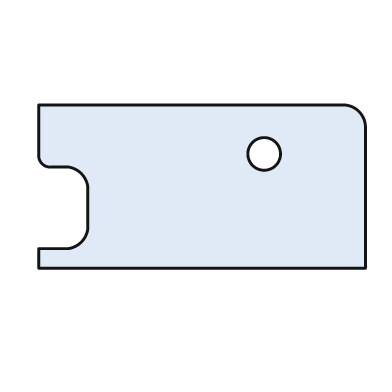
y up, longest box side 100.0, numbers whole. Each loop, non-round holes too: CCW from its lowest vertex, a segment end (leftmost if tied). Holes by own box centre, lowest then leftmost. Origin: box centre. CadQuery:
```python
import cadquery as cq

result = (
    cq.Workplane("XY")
    .moveTo(-50.0, -25.0)
    .lineTo(50.0, -25.0)
    .lineTo(50.0, 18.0)
    .threePointArc((48.0, 23.0), (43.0, 25.0))
    .lineTo(-50.0, 25.0)
    .lineTo(-50.0, 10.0)
    .threePointArc((-49.0, 7.0), (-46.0, 6.0))
    .lineTo(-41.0, 6.0)
    .threePointArc((-37.0, 4.0), (-35.0, 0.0))
    .lineTo(-35.0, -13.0)
    .threePointArc((-37.0, -17.0), (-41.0, -19.0))
    .lineTo(-50.0, -19.0)
    .close()
    .moveTo(19.0, 10.0)
    .circle(5.0)
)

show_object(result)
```